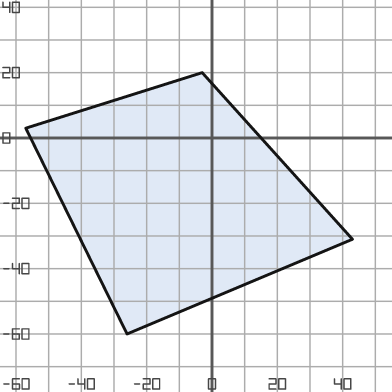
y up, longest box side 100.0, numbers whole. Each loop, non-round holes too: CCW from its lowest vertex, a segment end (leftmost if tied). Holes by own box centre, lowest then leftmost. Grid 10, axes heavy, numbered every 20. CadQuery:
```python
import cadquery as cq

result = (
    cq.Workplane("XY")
    .moveTo(-26.0, -60.0)
    .lineTo(43.0, -31.0)
    .lineTo(-3.0, 20.0)
    .lineTo(-57.0, 3.0)
    .close()
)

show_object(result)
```